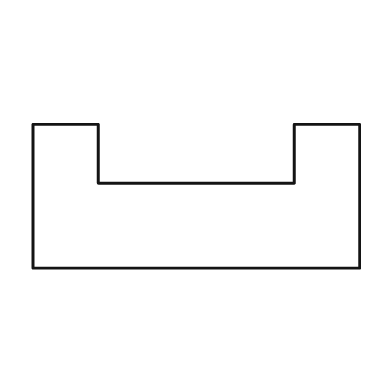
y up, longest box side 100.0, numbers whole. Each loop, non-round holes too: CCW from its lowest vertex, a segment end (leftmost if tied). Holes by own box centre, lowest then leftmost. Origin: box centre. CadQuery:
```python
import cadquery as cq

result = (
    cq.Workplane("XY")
    .moveTo(-50.0, -22.0)
    .lineTo(50.0, -22.0)
    .lineTo(50.0, 22.0)
    .lineTo(30.0, 22.0)
    .lineTo(30.0, 4.0)
    .lineTo(-30.0, 4.0)
    .lineTo(-30.0, 22.0)
    .lineTo(-50.0, 22.0)
    .close()
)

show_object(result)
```